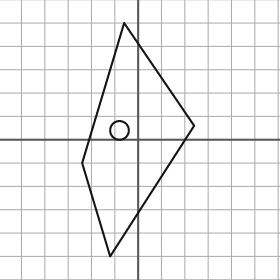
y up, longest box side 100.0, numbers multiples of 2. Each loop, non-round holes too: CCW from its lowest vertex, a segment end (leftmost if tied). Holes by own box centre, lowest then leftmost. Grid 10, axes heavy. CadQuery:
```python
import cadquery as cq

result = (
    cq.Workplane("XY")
    .moveTo(-12.0, -50.0)
    .lineTo(24.0, 6.0)
    .lineTo(-6.0, 50.0)
    .lineTo(-24.0, -10.0)
    .close()
    .moveTo(-8.0, 4.0)
    .circle(4.0)
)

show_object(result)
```